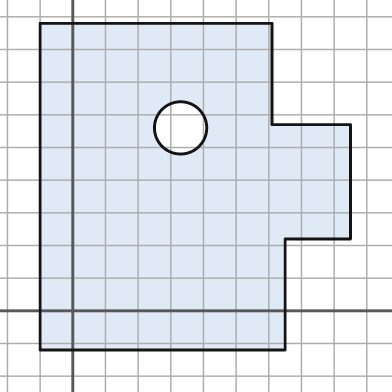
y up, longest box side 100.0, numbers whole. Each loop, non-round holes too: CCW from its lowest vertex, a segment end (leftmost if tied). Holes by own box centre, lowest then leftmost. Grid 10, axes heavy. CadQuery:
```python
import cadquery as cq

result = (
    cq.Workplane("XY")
    .moveTo(-10.0, -12.0)
    .lineTo(65.0, -12.0)
    .lineTo(65.0, 22.0)
    .lineTo(85.0, 22.0)
    .lineTo(85.0, 57.0)
    .lineTo(61.0, 57.0)
    .lineTo(61.0, 88.0)
    .lineTo(-10.0, 88.0)
    .close()
    .moveTo(33.0, 56.0)
    .circle(8.0)
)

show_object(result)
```